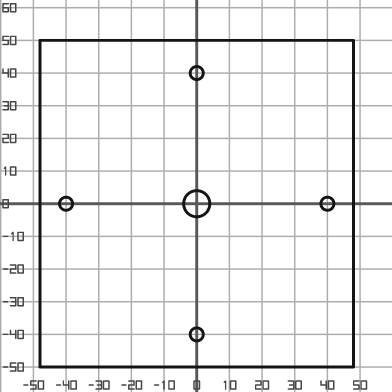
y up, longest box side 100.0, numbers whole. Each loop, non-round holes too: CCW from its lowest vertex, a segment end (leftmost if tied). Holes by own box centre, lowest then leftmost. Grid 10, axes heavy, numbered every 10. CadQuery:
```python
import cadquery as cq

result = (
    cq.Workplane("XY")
    .moveTo(-48.0, -50.0)
    .lineTo(48.0, -50.0)
    .lineTo(48.0, 50.0)
    .lineTo(-48.0, 50.0)
    .close()
    .moveTo(0.0, -40.0)
    .circle(2.0)
    .moveTo(-40.0, 0.0)
    .circle(2.0)
    .moveTo(0.0, 0.0)
    .circle(4.0)
    .moveTo(40.0, 0.0)
    .circle(2.0)
    .moveTo(0.0, 40.0)
    .circle(2.0)
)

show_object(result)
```